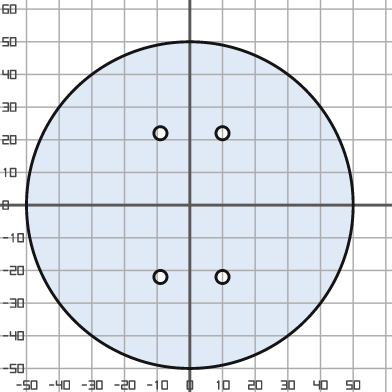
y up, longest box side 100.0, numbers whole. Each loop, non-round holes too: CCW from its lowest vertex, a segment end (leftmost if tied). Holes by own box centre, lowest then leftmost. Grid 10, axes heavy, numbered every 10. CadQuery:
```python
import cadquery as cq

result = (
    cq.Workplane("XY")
    .moveTo(0.0, 0.0)
    .circle(50.0)
    .moveTo(-9.0, -22.0)
    .circle(2.0)
    .moveTo(10.0, -22.0)
    .circle(2.0)
    .moveTo(-9.0, 22.0)
    .circle(2.0)
    .moveTo(10.0, 22.0)
    .circle(2.0)
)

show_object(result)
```